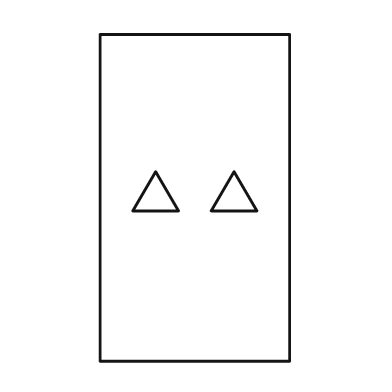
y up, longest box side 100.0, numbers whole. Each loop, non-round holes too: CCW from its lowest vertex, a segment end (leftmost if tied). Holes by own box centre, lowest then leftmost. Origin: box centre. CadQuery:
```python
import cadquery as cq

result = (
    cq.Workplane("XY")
    .moveTo(-29.0, -50.0)
    .lineTo(29.0, -50.0)
    .lineTo(29.0, 50.0)
    .lineTo(-29.0, 50.0)
    .close()
    .moveTo(-19.0, -4.0)
    .lineTo(-5.0, -4.0)
    .lineTo(-12.0, 8.0)
    .close()
    .moveTo(5.0, -4.0)
    .lineTo(19.0, -4.0)
    .lineTo(12.0, 8.0)
    .close()
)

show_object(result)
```